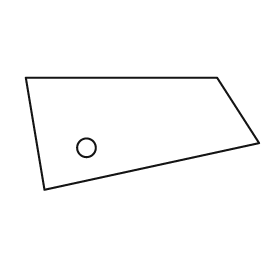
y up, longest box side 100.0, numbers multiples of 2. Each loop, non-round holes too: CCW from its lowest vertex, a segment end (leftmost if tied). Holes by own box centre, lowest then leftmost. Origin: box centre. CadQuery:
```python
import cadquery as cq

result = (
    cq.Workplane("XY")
    .moveTo(-42.0, -24.0)
    .lineTo(50.0, -4.0)
    .lineTo(32.0, 24.0)
    .lineTo(-50.0, 24.0)
    .close()
    .moveTo(-24.0, -6.0)
    .circle(4.0)
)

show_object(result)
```